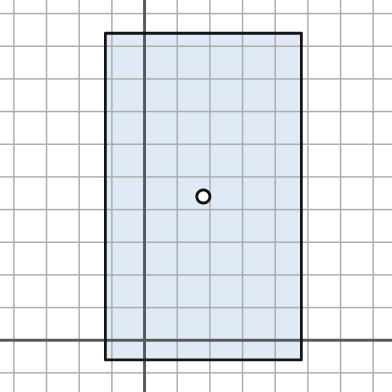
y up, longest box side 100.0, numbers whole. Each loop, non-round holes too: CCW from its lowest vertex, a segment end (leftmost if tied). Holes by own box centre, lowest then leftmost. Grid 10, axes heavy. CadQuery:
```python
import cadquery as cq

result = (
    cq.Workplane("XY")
    .moveTo(-12.0, -6.0)
    .lineTo(48.0, -6.0)
    .lineTo(48.0, 94.0)
    .lineTo(-12.0, 94.0)
    .close()
    .moveTo(18.0, 44.0)
    .circle(2.0)
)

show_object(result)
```